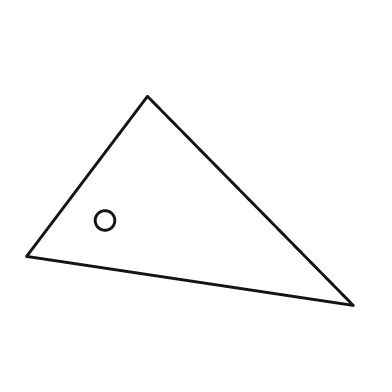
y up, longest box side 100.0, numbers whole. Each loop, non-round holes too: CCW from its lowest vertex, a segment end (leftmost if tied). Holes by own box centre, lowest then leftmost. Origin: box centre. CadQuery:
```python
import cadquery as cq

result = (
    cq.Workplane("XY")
    .moveTo(50.0, -32.0)
    .lineTo(-13.0, 32.0)
    .lineTo(-50.0, -17.0)
    .close()
    .moveTo(-26.0, -6.0)
    .circle(3.0)
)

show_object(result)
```